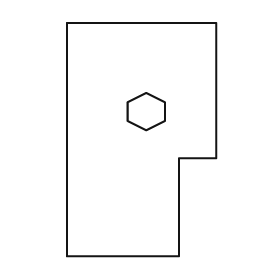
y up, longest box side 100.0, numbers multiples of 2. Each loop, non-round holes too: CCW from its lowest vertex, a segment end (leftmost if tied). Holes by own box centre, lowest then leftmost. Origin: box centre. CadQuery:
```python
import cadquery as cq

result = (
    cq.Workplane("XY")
    .moveTo(-32.0, -50.0)
    .lineTo(16.0, -50.0)
    .lineTo(16.0, -8.0)
    .lineTo(32.0, -8.0)
    .lineTo(32.0, 50.0)
    .lineTo(-32.0, 50.0)
    .close()
    .moveTo(2.0, 4.0)
    .lineTo(10.0, 8.0)
    .lineTo(10.0, 16.0)
    .lineTo(2.0, 20.0)
    .lineTo(-6.0, 16.0)
    .lineTo(-6.0, 8.0)
    .close()
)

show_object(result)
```